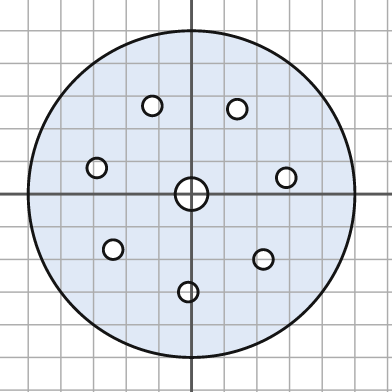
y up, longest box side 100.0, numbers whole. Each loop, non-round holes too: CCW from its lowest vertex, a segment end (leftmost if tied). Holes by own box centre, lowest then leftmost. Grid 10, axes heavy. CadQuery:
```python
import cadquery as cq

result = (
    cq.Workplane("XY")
    .moveTo(0.0, 0.0)
    .circle(50.0)
    .moveTo(-1.0, -30.0)
    .circle(3.0)
    .moveTo(22.0, -20.0)
    .circle(3.0)
    .moveTo(-24.0, -17.0)
    .circle(3.0)
    .moveTo(0.0, 0.0)
    .circle(5.0)
    .moveTo(29.0, 5.0)
    .circle(3.0)
    .moveTo(-29.0, 8.0)
    .circle(3.0)
    .moveTo(14.0, 26.0)
    .circle(3.0)
    .moveTo(-12.0, 27.0)
    .circle(3.0)
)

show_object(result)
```